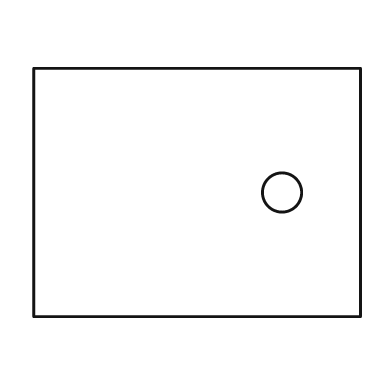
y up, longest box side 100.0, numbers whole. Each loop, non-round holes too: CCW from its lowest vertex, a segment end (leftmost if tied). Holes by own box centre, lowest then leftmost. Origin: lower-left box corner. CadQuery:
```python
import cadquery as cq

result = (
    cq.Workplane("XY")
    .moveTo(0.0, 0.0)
    .lineTo(100.0, 0.0)
    .lineTo(100.0, 76.0)
    .lineTo(0.0, 76.0)
    .close()
    .moveTo(76.0, 38.0)
    .circle(6.0)
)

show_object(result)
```